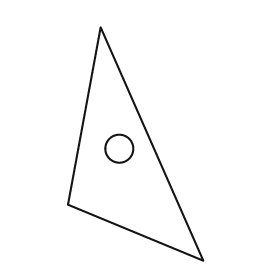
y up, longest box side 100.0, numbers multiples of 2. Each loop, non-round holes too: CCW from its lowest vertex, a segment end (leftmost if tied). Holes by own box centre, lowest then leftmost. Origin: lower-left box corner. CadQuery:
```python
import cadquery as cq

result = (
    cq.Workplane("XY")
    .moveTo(58.0, 0.0)
    .lineTo(14.0, 100.0)
    .lineTo(0.0, 24.0)
    .close()
    .moveTo(22.0, 48.0)
    .circle(6.0)
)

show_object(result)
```